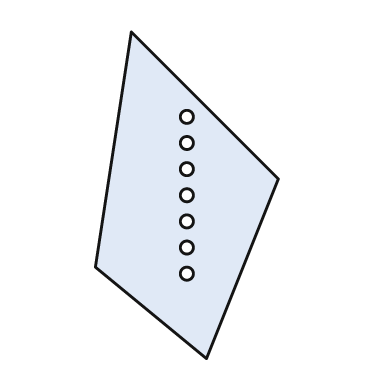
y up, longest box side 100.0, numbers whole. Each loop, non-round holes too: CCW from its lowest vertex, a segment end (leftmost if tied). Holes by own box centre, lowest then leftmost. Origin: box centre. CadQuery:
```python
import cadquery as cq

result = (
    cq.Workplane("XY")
    .moveTo(6.0, -50.0)
    .lineTo(28.0, 5.0)
    .lineTo(-17.0, 50.0)
    .lineTo(-28.0, -22.0)
    .close()
    .moveTo(0.0, -24.0)
    .circle(2.0)
    .moveTo(0.0, -16.0)
    .circle(2.0)
    .moveTo(0.0, -8.0)
    .circle(2.0)
    .moveTo(0.0, 0.0)
    .circle(2.0)
    .moveTo(0.0, 8.0)
    .circle(2.0)
    .moveTo(0.0, 16.0)
    .circle(2.0)
    .moveTo(0.0, 24.0)
    .circle(2.0)
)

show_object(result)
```